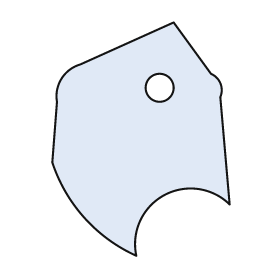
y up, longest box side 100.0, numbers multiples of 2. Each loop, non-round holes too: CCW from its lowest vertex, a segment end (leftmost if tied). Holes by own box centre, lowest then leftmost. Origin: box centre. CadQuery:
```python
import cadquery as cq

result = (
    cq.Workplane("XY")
    .moveTo(-2.0, -50.0)
    .threePointArc((10.0, -24.0), (38.0, -28.0))
    .lineTo(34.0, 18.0)
    .threePointArc((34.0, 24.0), (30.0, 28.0))
    .lineTo(14.0, 50.0)
    .lineTo(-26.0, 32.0)
    .threePointArc((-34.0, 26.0), (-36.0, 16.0))
    .lineTo(-38.0, -10.0)
    .threePointArc((-24.0, -34.0), (-2.0, -50.0))
    .close()
    .moveTo(8.0, 22.0)
    .circle(6.0)
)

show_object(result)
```